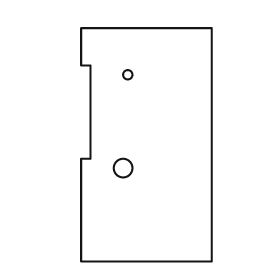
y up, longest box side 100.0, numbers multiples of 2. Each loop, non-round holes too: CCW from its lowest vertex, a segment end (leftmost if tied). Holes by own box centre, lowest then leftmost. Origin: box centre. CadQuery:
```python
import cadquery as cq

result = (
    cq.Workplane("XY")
    .moveTo(-28.0, -50.0)
    .lineTo(28.0, -50.0)
    .lineTo(28.0, 50.0)
    .lineTo(-28.0, 50.0)
    .lineTo(-28.0, 34.0)
    .lineTo(-24.0, 34.0)
    .lineTo(-24.0, -6.0)
    .lineTo(-28.0, -6.0)
    .close()
    .moveTo(-10.0, -10.0)
    .circle(4.0)
    .moveTo(-8.0, 30.0)
    .circle(2.0)
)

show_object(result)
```